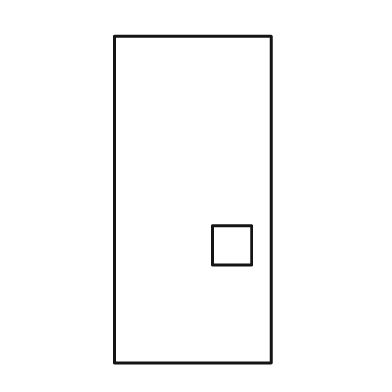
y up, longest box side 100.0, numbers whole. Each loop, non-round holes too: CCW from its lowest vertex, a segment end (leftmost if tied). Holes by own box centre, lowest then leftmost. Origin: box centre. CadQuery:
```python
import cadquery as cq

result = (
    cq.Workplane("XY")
    .moveTo(-24.0, -50.0)
    .lineTo(24.0, -50.0)
    .lineTo(24.0, 50.0)
    .lineTo(-24.0, 50.0)
    .close()
    .moveTo(6.0, -20.0)
    .lineTo(18.0, -20.0)
    .lineTo(18.0, -8.0)
    .lineTo(6.0, -8.0)
    .close()
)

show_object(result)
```